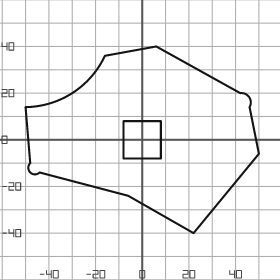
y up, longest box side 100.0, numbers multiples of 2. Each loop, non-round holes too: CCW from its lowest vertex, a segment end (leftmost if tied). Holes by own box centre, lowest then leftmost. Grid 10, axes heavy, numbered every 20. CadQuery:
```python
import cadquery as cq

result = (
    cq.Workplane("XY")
    .moveTo(22.0, -40.0)
    .lineTo(50.0, -6.0)
    .lineTo(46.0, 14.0)
    .threePointArc((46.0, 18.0), (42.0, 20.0))
    .lineTo(6.0, 40.0)
    .lineTo(-16.0, 36.0)
    .threePointArc((-30.0, 20.0), (-50.0, 14.0))
    .lineTo(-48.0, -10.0)
    .threePointArc((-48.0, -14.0), (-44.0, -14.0))
    .lineTo(-6.0, -24.0)
    .close()
    .moveTo(-8.0, -8.0)
    .lineTo(8.0, -8.0)
    .lineTo(8.0, 8.0)
    .lineTo(-8.0, 8.0)
    .close()
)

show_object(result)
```